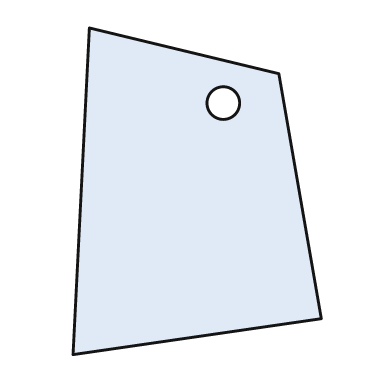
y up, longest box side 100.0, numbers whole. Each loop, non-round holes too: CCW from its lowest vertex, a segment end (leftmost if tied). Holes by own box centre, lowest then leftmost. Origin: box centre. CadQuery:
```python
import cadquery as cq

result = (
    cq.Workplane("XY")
    .moveTo(-38.0, -50.0)
    .lineTo(38.0, -39.0)
    .lineTo(25.0, 36.0)
    .lineTo(-33.0, 50.0)
    .close()
    .moveTo(8.0, 27.0)
    .circle(5.0)
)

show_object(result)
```